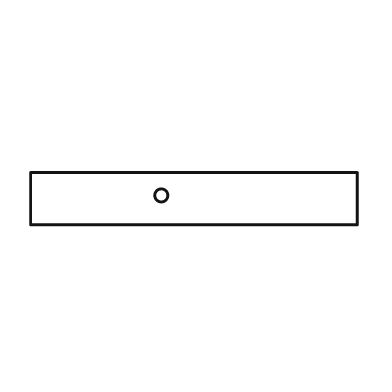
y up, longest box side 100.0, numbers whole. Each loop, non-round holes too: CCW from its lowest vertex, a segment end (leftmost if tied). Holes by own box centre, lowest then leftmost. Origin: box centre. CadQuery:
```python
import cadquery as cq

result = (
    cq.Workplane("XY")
    .moveTo(-50.0, -8.0)
    .lineTo(50.0, -8.0)
    .lineTo(50.0, 8.0)
    .lineTo(-50.0, 8.0)
    .close()
    .moveTo(-10.0, 1.0)
    .circle(2.0)
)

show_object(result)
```